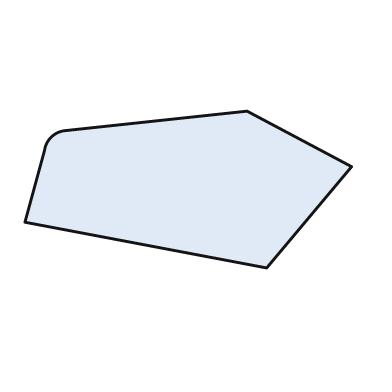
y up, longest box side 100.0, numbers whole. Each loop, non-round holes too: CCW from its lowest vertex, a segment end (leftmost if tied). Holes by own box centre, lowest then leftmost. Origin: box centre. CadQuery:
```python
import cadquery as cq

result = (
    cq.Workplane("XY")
    .moveTo(24.0, -24.0)
    .lineTo(50.0, 7.0)
    .lineTo(18.0, 24.0)
    .lineTo(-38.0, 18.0)
    .threePointArc((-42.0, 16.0), (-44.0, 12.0))
    .lineTo(-50.0, -10.0)
    .close()
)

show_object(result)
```